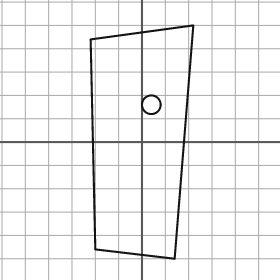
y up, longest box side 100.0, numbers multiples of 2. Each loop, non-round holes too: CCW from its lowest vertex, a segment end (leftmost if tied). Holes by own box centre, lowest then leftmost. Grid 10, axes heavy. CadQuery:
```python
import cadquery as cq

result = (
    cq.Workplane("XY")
    .moveTo(14.0, -50.0)
    .lineTo(22.0, 50.0)
    .lineTo(-22.0, 44.0)
    .lineTo(-20.0, -46.0)
    .close()
    .moveTo(4.0, 16.0)
    .circle(4.0)
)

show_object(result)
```